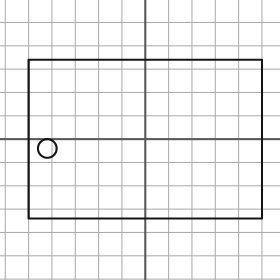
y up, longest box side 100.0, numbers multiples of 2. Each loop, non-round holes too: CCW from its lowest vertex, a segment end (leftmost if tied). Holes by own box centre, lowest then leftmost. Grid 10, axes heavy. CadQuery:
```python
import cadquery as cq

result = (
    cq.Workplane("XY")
    .moveTo(-50.0, -34.0)
    .lineTo(50.0, -34.0)
    .lineTo(50.0, 34.0)
    .lineTo(-50.0, 34.0)
    .close()
    .moveTo(-42.0, -4.0)
    .circle(4.0)
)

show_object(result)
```